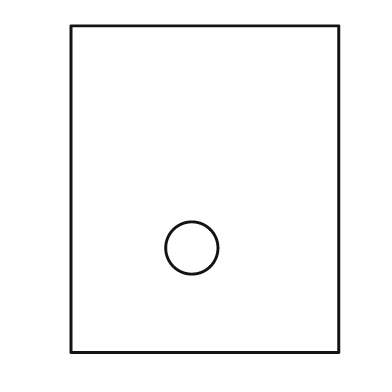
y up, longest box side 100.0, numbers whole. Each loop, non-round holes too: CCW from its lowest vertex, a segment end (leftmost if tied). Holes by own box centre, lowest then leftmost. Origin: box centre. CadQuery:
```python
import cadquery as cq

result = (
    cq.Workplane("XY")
    .moveTo(-41.0, -50.0)
    .lineTo(41.0, -50.0)
    .lineTo(41.0, 50.0)
    .lineTo(-41.0, 50.0)
    .close()
    .moveTo(-4.0, -18.0)
    .circle(8.0)
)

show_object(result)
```